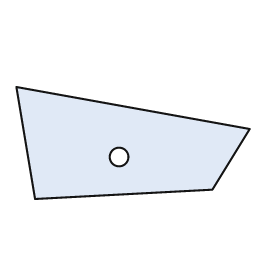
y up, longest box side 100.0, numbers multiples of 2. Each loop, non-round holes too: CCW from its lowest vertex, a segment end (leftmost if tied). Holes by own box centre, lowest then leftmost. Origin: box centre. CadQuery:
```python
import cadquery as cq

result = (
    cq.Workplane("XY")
    .moveTo(-42.0, -24.0)
    .lineTo(34.0, -20.0)
    .lineTo(50.0, 6.0)
    .lineTo(-50.0, 24.0)
    .close()
    .moveTo(-6.0, -6.0)
    .circle(4.0)
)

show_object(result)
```